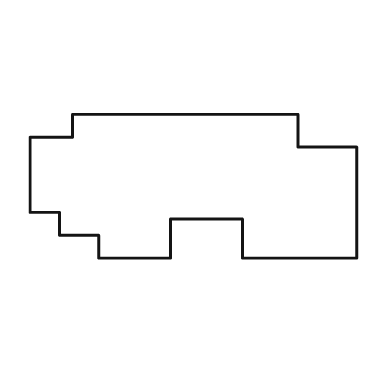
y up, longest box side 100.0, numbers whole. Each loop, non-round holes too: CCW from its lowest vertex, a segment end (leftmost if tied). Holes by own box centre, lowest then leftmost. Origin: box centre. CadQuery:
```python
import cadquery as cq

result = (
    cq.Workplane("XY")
    .moveTo(-29.0, -22.0)
    .lineTo(-7.0, -22.0)
    .lineTo(-7.0, -10.0)
    .lineTo(15.0, -10.0)
    .lineTo(15.0, -22.0)
    .lineTo(50.0, -22.0)
    .lineTo(50.0, 12.0)
    .lineTo(32.0, 12.0)
    .lineTo(32.0, 22.0)
    .lineTo(-37.0, 22.0)
    .lineTo(-37.0, 15.0)
    .lineTo(-50.0, 15.0)
    .lineTo(-50.0, -8.0)
    .lineTo(-41.0, -8.0)
    .lineTo(-41.0, -15.0)
    .lineTo(-29.0, -15.0)
    .close()
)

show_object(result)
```